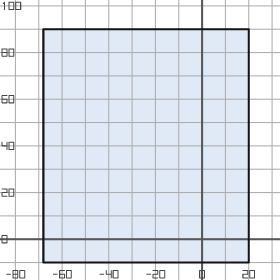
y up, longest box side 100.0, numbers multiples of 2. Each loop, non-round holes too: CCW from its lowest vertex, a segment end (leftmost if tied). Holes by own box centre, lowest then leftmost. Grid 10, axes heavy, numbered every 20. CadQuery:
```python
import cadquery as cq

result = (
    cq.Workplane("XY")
    .moveTo(-68.0, -10.0)
    .lineTo(20.0, -10.0)
    .lineTo(20.0, 90.0)
    .lineTo(-68.0, 90.0)
    .close()
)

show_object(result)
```